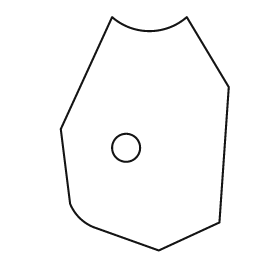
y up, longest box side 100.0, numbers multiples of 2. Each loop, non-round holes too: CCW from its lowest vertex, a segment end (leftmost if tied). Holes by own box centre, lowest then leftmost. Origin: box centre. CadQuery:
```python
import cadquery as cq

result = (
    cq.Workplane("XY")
    .moveTo(6.0, -50.0)
    .lineTo(32.0, -38.0)
    .lineTo(36.0, 20.0)
    .lineTo(18.0, 50.0)
    .threePointArc((2.0, 44.0), (-14.0, 50.0))
    .lineTo(-36.0, 2.0)
    .lineTo(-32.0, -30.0)
    .threePointArc((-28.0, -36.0), (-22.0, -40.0))
    .close()
    .moveTo(-8.0, -6.0)
    .circle(6.0)
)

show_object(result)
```